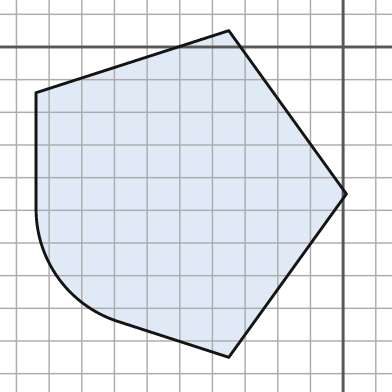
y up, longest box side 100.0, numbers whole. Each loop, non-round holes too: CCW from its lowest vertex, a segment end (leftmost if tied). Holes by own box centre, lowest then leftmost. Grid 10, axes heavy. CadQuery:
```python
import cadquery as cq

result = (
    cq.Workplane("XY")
    .moveTo(-35.0, -95.0)
    .lineTo(1.0, -45.0)
    .lineTo(-35.0, 5.0)
    .lineTo(-94.0, -14.0)
    .lineTo(-94.0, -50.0)
    .threePointArc((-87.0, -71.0), (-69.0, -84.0))
    .close()
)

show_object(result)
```